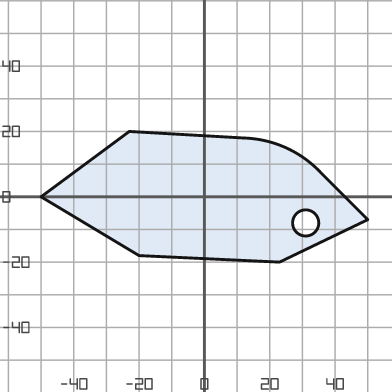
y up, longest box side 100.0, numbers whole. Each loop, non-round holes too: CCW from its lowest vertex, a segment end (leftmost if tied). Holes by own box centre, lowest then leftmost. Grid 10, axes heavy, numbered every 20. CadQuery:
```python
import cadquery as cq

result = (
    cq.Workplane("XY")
    .moveTo(23.0, -20.0)
    .lineTo(50.0, -7.0)
    .lineTo(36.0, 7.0)
    .threePointArc((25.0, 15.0), (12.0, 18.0))
    .lineTo(-23.0, 20.0)
    .lineTo(-50.0, 0.0)
    .lineTo(-20.0, -18.0)
    .close()
    .moveTo(31.0, -8.0)
    .circle(4.0)
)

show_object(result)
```